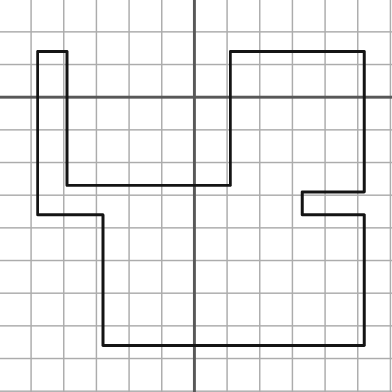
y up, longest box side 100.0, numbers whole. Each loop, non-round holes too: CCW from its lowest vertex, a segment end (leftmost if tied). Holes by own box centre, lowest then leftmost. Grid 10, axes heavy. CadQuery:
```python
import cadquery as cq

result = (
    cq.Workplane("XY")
    .moveTo(-28.0, -76.0)
    .lineTo(52.0, -76.0)
    .lineTo(52.0, -36.0)
    .lineTo(33.0, -36.0)
    .lineTo(33.0, -29.0)
    .lineTo(52.0, -29.0)
    .lineTo(52.0, 14.0)
    .lineTo(11.0, 14.0)
    .lineTo(11.0, -27.0)
    .lineTo(-39.0, -27.0)
    .lineTo(-39.0, 14.0)
    .lineTo(-48.0, 14.0)
    .lineTo(-48.0, -36.0)
    .lineTo(-28.0, -36.0)
    .close()
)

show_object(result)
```